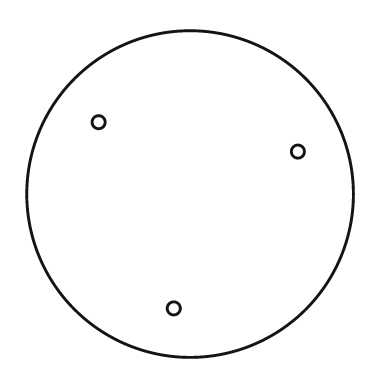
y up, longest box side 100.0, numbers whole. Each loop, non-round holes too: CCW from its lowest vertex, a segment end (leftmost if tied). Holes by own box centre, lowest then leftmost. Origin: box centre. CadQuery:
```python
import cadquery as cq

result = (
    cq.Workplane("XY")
    .moveTo(0.0, 0.0)
    .circle(50.0)
    .moveTo(-5.0, -35.0)
    .circle(2.0)
    .moveTo(33.0, 13.0)
    .circle(2.0)
    .moveTo(-28.0, 22.0)
    .circle(2.0)
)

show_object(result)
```